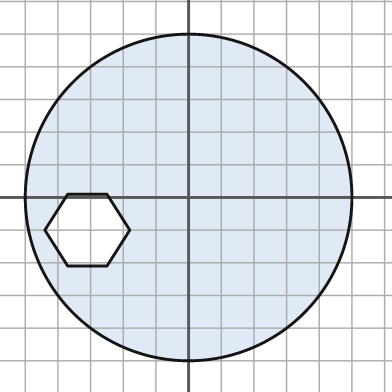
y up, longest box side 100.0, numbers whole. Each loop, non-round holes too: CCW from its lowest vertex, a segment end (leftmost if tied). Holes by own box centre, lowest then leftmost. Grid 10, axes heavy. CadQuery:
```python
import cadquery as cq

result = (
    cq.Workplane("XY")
    .moveTo(0.0, 0.0)
    .circle(50.0)
    .moveTo(-37.0, -21.0)
    .lineTo(-25.0, -21.0)
    .lineTo(-18.0, -10.0)
    .lineTo(-25.0, 1.0)
    .lineTo(-37.0, 1.0)
    .lineTo(-44.0, -10.0)
    .close()
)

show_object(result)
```